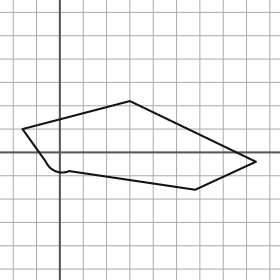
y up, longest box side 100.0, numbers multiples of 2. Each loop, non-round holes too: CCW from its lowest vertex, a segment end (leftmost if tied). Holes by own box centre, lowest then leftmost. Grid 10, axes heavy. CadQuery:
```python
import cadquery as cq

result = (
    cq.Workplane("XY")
    .moveTo(58.0, -16.0)
    .lineTo(84.0, -4.0)
    .lineTo(30.0, 22.0)
    .lineTo(-16.0, 10.0)
    .lineTo(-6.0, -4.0)
    .threePointArc((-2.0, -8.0), (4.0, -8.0))
    .close()
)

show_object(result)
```